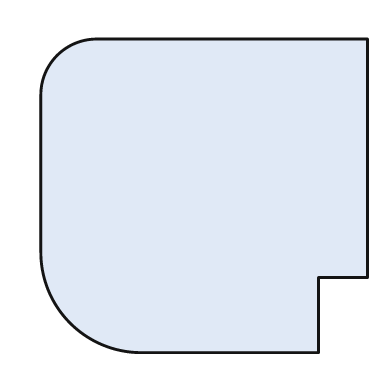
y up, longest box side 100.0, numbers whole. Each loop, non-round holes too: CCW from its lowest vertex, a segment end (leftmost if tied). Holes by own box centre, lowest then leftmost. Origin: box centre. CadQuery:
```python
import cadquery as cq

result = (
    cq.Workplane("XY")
    .moveTo(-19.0, -48.0)
    .lineTo(35.0, -48.0)
    .lineTo(35.0, -25.0)
    .lineTo(50.0, -25.0)
    .lineTo(50.0, 48.0)
    .lineTo(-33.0, 48.0)
    .threePointArc((-45.0, 43.0), (-50.0, 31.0))
    .lineTo(-50.0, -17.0)
    .threePointArc((-41.0, -39.0), (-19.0, -48.0))
    .close()
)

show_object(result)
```